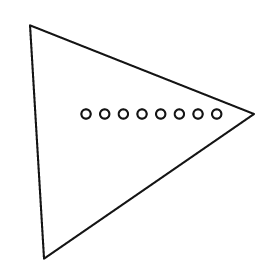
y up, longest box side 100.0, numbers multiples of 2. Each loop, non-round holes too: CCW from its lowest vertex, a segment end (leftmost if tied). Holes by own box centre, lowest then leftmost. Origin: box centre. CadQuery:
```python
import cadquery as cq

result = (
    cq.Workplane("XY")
    .moveTo(-42.0, -50.0)
    .lineTo(48.0, 12.0)
    .lineTo(-48.0, 50.0)
    .close()
    .moveTo(-24.0, 12.0)
    .circle(2.0)
    .moveTo(-16.0, 12.0)
    .circle(2.0)
    .moveTo(-8.0, 12.0)
    .circle(2.0)
    .moveTo(0.0, 12.0)
    .circle(2.0)
    .moveTo(8.0, 12.0)
    .circle(2.0)
    .moveTo(16.0, 12.0)
    .circle(2.0)
    .moveTo(24.0, 12.0)
    .circle(2.0)
    .moveTo(32.0, 12.0)
    .circle(2.0)
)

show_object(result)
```